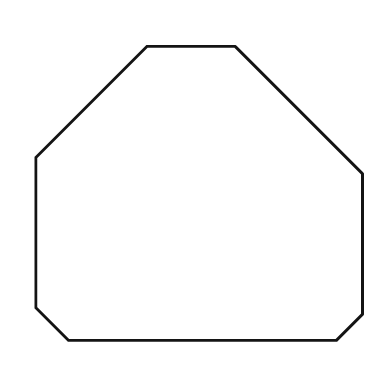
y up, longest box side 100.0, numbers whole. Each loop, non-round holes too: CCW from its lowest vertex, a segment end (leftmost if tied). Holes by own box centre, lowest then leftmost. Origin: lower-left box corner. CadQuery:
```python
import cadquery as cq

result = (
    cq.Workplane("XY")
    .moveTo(10.0, 0.0)
    .lineTo(92.0, 0.0)
    .lineTo(100.0, 8.0)
    .lineTo(100.0, 51.0)
    .lineTo(61.0, 90.0)
    .lineTo(34.0, 90.0)
    .lineTo(0.0, 56.0)
    .lineTo(0.0, 10.0)
    .close()
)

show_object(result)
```